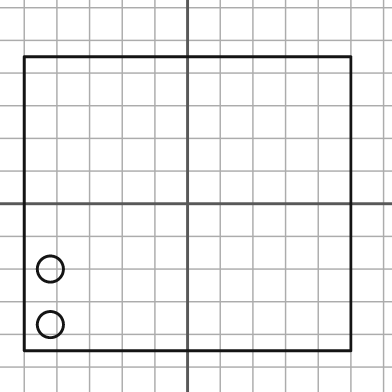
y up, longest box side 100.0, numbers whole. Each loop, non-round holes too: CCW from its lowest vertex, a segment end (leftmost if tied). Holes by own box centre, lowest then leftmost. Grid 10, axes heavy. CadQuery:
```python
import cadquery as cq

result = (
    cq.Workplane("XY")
    .moveTo(-50.0, -45.0)
    .lineTo(50.0, -45.0)
    .lineTo(50.0, 45.0)
    .lineTo(-50.0, 45.0)
    .close()
    .moveTo(-42.0, -37.0)
    .circle(4.0)
    .moveTo(-42.0, -20.0)
    .circle(4.0)
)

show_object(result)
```